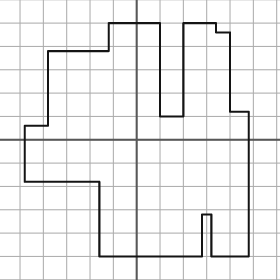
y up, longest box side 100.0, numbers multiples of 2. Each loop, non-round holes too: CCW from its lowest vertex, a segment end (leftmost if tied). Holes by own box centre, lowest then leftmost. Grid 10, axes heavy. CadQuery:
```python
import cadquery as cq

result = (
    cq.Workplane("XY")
    .moveTo(-16.0, -50.0)
    .lineTo(28.0, -50.0)
    .lineTo(28.0, -32.0)
    .lineTo(32.0, -32.0)
    .lineTo(32.0, -50.0)
    .lineTo(48.0, -50.0)
    .lineTo(48.0, 12.0)
    .lineTo(40.0, 12.0)
    .lineTo(40.0, 46.0)
    .lineTo(34.0, 46.0)
    .lineTo(34.0, 50.0)
    .lineTo(20.0, 50.0)
    .lineTo(20.0, 10.0)
    .lineTo(10.0, 10.0)
    .lineTo(10.0, 50.0)
    .lineTo(-12.0, 50.0)
    .lineTo(-12.0, 38.0)
    .lineTo(-38.0, 38.0)
    .lineTo(-38.0, 6.0)
    .lineTo(-48.0, 6.0)
    .lineTo(-48.0, -18.0)
    .lineTo(-16.0, -18.0)
    .close()
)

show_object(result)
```